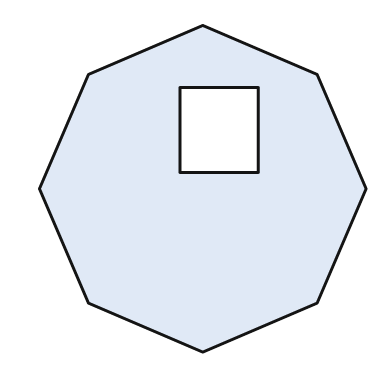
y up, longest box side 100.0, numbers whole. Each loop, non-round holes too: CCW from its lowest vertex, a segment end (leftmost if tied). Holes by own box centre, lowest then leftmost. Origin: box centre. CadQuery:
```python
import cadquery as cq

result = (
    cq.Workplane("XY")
    .moveTo(0.0, -50.0)
    .lineTo(35.0, -35.0)
    .lineTo(50.0, 0.0)
    .lineTo(35.0, 35.0)
    .lineTo(0.0, 50.0)
    .lineTo(-35.0, 35.0)
    .lineTo(-50.0, 0.0)
    .lineTo(-35.0, -35.0)
    .close()
    .moveTo(-7.0, 5.0)
    .lineTo(17.0, 5.0)
    .lineTo(17.0, 31.0)
    .lineTo(-7.0, 31.0)
    .close()
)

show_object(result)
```